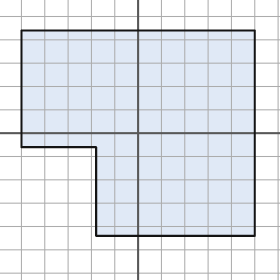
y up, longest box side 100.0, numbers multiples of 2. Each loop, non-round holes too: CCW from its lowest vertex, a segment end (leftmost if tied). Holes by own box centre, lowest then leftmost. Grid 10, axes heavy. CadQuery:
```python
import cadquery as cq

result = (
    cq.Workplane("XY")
    .moveTo(-18.0, -44.0)
    .lineTo(50.0, -44.0)
    .lineTo(50.0, 44.0)
    .lineTo(-50.0, 44.0)
    .lineTo(-50.0, -6.0)
    .lineTo(-18.0, -6.0)
    .close()
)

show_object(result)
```